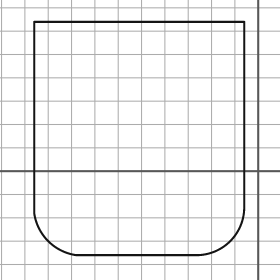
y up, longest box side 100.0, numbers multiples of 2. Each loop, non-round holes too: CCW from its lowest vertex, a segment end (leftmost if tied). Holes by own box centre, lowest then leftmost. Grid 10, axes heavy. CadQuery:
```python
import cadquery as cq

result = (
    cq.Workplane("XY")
    .moveTo(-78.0, -36.0)
    .lineTo(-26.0, -36.0)
    .threePointArc((-12.0, -30.0), (-6.0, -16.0))
    .lineTo(-6.0, 64.0)
    .lineTo(-96.0, 64.0)
    .lineTo(-96.0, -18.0)
    .threePointArc((-90.0, -30.0), (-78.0, -36.0))
    .close()
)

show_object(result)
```